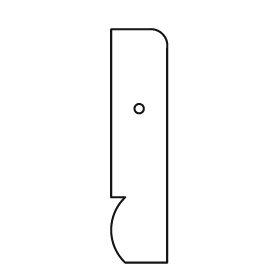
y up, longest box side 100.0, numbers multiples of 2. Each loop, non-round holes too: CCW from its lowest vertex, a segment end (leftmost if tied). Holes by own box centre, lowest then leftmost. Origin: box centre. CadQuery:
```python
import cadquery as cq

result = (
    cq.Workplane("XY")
    .moveTo(-6.0, -50.0)
    .lineTo(12.0, -50.0)
    .lineTo(12.0, 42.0)
    .threePointArc((10.0, 48.0), (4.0, 50.0))
    .lineTo(-12.0, 50.0)
    .lineTo(-12.0, -22.0)
    .lineTo(-6.0, -22.0)
    .threePointArc((-12.0, -36.0), (-6.0, -50.0))
    .close()
    .moveTo(0.0, 16.0)
    .circle(2.0)
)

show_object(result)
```